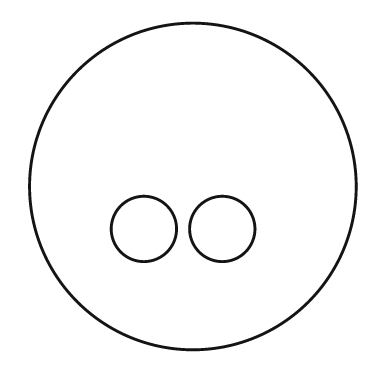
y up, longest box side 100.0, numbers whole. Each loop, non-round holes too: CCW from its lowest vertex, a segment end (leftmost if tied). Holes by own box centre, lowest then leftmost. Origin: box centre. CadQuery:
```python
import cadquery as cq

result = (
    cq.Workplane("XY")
    .moveTo(0.0, 0.0)
    .circle(50.0)
    .moveTo(-15.0, -13.0)
    .circle(10.0)
    .moveTo(9.0, -13.0)
    .circle(10.0)
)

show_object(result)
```